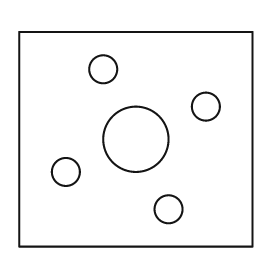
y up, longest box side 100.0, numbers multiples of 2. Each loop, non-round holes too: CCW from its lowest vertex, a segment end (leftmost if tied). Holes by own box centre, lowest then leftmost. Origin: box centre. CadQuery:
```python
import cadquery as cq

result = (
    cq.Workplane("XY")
    .moveTo(-50.0, -46.0)
    .lineTo(50.0, -46.0)
    .lineTo(50.0, 46.0)
    .lineTo(-50.0, 46.0)
    .close()
    .moveTo(14.0, -30.0)
    .circle(6.0)
    .moveTo(-30.0, -14.0)
    .circle(6.0)
    .moveTo(0.0, 0.0)
    .circle(14.0)
    .moveTo(30.0, 14.0)
    .circle(6.0)
    .moveTo(-14.0, 30.0)
    .circle(6.0)
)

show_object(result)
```